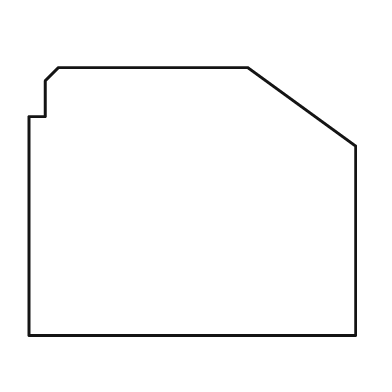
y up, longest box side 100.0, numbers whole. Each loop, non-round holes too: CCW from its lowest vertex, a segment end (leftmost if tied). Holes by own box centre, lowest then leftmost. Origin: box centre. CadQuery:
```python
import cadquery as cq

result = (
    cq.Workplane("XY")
    .moveTo(-50.0, -41.0)
    .lineTo(50.0, -41.0)
    .lineTo(50.0, 17.0)
    .lineTo(17.0, 41.0)
    .lineTo(-41.0, 41.0)
    .lineTo(-45.0, 37.0)
    .lineTo(-45.0, 26.0)
    .lineTo(-50.0, 26.0)
    .close()
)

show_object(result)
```